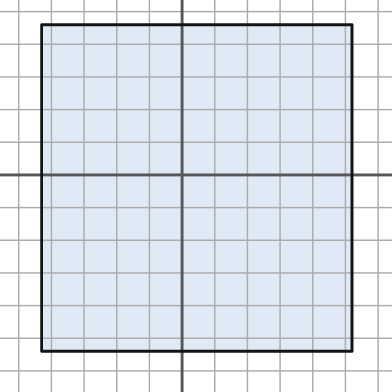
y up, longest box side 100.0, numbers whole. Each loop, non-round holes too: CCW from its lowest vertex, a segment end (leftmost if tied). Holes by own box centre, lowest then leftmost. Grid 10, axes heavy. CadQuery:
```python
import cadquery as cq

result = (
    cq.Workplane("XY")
    .moveTo(-43.0, -54.0)
    .lineTo(52.0, -54.0)
    .lineTo(52.0, 46.0)
    .lineTo(-43.0, 46.0)
    .close()
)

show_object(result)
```